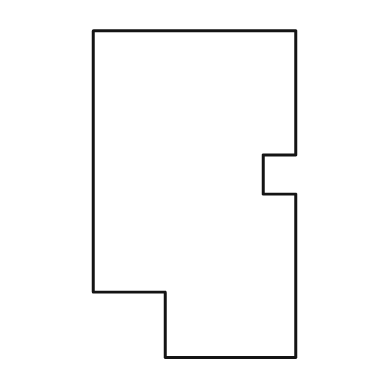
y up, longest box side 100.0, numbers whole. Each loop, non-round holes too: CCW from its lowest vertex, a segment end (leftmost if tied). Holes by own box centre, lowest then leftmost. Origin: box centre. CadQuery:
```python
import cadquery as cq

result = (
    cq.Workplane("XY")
    .moveTo(-9.0, -50.0)
    .lineTo(31.0, -50.0)
    .lineTo(31.0, 0.0)
    .lineTo(21.0, 0.0)
    .lineTo(21.0, 12.0)
    .lineTo(31.0, 12.0)
    .lineTo(31.0, 50.0)
    .lineTo(-31.0, 50.0)
    .lineTo(-31.0, -30.0)
    .lineTo(-9.0, -30.0)
    .close()
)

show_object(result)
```